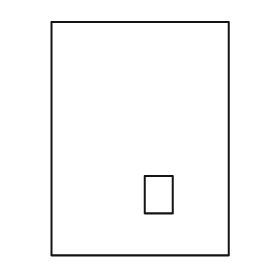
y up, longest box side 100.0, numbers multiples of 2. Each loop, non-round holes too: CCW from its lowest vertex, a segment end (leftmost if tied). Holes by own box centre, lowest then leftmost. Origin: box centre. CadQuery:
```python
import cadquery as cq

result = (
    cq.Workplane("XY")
    .moveTo(-38.0, -50.0)
    .lineTo(38.0, -50.0)
    .lineTo(38.0, 50.0)
    .lineTo(-38.0, 50.0)
    .close()
    .moveTo(2.0, -32.0)
    .lineTo(14.0, -32.0)
    .lineTo(14.0, -16.0)
    .lineTo(2.0, -16.0)
    .close()
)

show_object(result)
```